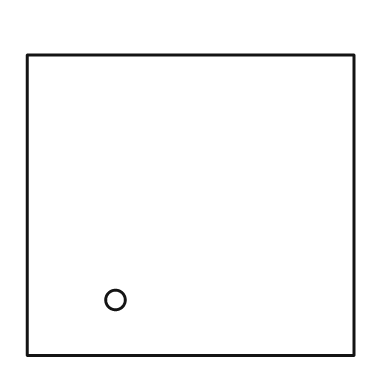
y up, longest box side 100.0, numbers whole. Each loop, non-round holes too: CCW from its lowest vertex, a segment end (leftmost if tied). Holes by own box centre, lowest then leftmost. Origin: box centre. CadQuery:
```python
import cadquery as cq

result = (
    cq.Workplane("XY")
    .moveTo(-50.0, -46.0)
    .lineTo(50.0, -46.0)
    .lineTo(50.0, 46.0)
    .lineTo(-50.0, 46.0)
    .close()
    .moveTo(-23.0, -29.0)
    .circle(3.0)
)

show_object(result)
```